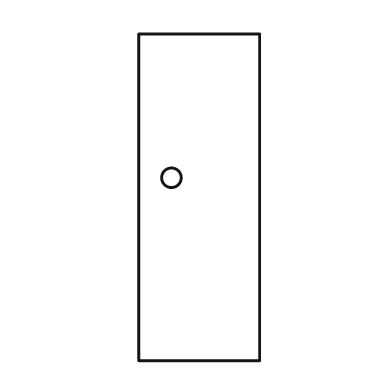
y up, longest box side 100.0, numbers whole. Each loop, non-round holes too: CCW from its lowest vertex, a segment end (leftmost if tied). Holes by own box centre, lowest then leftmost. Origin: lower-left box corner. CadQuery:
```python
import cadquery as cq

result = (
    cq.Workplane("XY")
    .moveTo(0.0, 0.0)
    .lineTo(37.0, 0.0)
    .lineTo(37.0, 100.0)
    .lineTo(0.0, 100.0)
    .close()
    .moveTo(10.0, 56.0)
    .circle(3.0)
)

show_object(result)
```